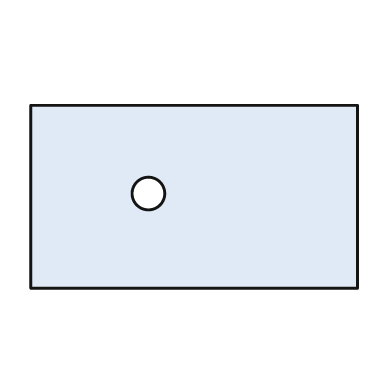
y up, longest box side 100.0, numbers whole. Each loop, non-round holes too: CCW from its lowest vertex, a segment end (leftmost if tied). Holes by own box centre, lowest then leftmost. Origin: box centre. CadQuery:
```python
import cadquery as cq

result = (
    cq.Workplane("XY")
    .moveTo(-50.0, -28.0)
    .lineTo(50.0, -28.0)
    .lineTo(50.0, 28.0)
    .lineTo(-50.0, 28.0)
    .close()
    .moveTo(-14.0, 1.0)
    .circle(5.0)
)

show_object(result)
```